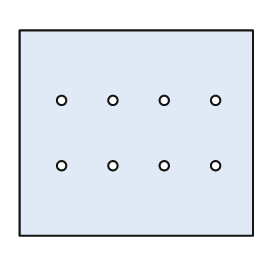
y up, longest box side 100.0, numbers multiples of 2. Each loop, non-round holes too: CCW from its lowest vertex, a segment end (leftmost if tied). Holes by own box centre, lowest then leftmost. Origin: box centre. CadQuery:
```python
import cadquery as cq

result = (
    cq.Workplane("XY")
    .moveTo(-50.0, -44.0)
    .lineTo(50.0, -44.0)
    .lineTo(50.0, 44.0)
    .lineTo(-50.0, 44.0)
    .close()
    .moveTo(-32.0, -14.0)
    .circle(2.0)
    .moveTo(-10.0, -14.0)
    .circle(2.0)
    .moveTo(12.0, -14.0)
    .circle(2.0)
    .moveTo(34.0, -14.0)
    .circle(2.0)
    .moveTo(-32.0, 14.0)
    .circle(2.0)
    .moveTo(-10.0, 14.0)
    .circle(2.0)
    .moveTo(12.0, 14.0)
    .circle(2.0)
    .moveTo(34.0, 14.0)
    .circle(2.0)
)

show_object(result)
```